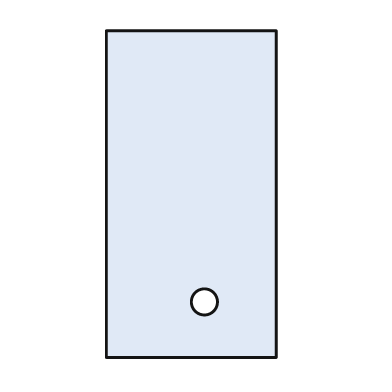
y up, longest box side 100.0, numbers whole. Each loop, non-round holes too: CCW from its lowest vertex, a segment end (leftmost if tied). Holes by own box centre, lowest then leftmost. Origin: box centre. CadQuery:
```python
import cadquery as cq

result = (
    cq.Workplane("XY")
    .moveTo(-26.0, -50.0)
    .lineTo(26.0, -50.0)
    .lineTo(26.0, 50.0)
    .lineTo(-26.0, 50.0)
    .close()
    .moveTo(4.0, -33.0)
    .circle(4.0)
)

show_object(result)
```